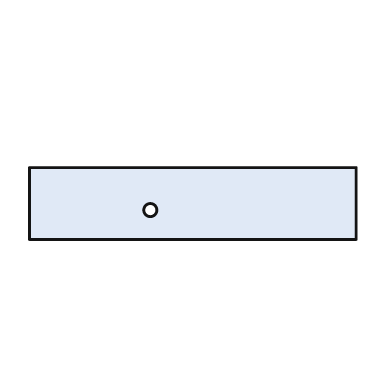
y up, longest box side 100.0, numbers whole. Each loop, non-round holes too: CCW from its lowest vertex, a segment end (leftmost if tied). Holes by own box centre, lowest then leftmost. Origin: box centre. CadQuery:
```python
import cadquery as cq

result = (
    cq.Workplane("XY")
    .moveTo(-50.0, -11.0)
    .lineTo(50.0, -11.0)
    .lineTo(50.0, 11.0)
    .lineTo(-50.0, 11.0)
    .close()
    .moveTo(-13.0, -2.0)
    .circle(2.0)
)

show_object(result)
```